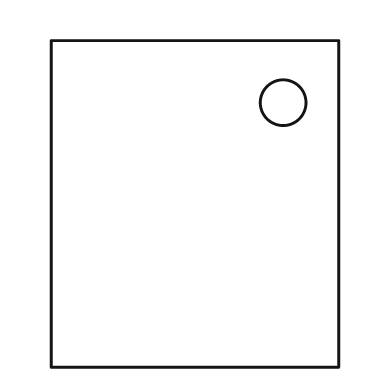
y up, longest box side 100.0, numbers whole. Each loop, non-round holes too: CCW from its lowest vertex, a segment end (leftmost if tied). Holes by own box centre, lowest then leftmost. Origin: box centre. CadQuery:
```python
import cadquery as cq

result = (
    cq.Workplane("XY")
    .moveTo(-44.0, -50.0)
    .lineTo(44.0, -50.0)
    .lineTo(44.0, 50.0)
    .lineTo(-44.0, 50.0)
    .close()
    .moveTo(27.0, 31.0)
    .circle(7.0)
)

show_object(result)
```